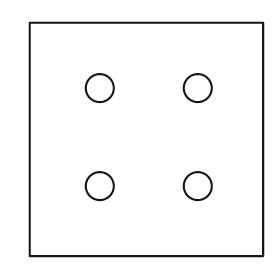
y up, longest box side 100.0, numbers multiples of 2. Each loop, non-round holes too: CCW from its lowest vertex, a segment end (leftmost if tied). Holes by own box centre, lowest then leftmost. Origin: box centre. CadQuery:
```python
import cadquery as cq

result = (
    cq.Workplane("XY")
    .moveTo(-50.0, -50.0)
    .lineTo(50.0, -50.0)
    .lineTo(50.0, 50.0)
    .lineTo(-50.0, 50.0)
    .close()
    .moveTo(-20.0, -20.0)
    .circle(6.0)
    .moveTo(22.0, -20.0)
    .circle(6.0)
    .moveTo(-20.0, 22.0)
    .circle(6.0)
    .moveTo(22.0, 22.0)
    .circle(6.0)
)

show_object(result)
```